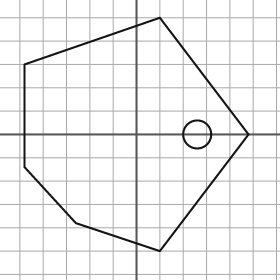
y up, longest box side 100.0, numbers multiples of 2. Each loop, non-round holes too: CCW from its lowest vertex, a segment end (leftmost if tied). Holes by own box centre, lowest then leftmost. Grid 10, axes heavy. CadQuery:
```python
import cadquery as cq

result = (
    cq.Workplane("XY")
    .moveTo(10.0, -50.0)
    .lineTo(48.0, 0.0)
    .lineTo(10.0, 50.0)
    .lineTo(-48.0, 30.0)
    .lineTo(-48.0, -14.0)
    .lineTo(-26.0, -38.0)
    .close()
    .moveTo(26.0, 0.0)
    .circle(6.0)
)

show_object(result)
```